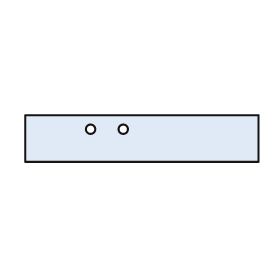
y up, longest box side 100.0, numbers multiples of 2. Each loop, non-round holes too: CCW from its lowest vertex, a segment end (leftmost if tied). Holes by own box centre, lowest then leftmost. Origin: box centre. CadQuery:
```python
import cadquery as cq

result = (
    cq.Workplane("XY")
    .moveTo(-50.0, -10.0)
    .lineTo(50.0, -10.0)
    .lineTo(50.0, 10.0)
    .lineTo(-50.0, 10.0)
    .close()
    .moveTo(-22.0, 4.0)
    .circle(2.0)
    .moveTo(-8.0, 4.0)
    .circle(2.0)
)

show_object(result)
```